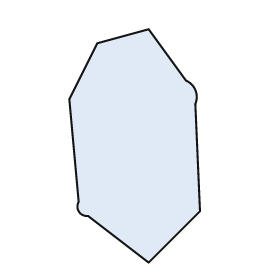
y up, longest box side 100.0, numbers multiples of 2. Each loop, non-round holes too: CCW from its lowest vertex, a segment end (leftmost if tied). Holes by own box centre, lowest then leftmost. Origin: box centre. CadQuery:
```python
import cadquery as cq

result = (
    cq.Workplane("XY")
    .moveTo(6.0, -50.0)
    .lineTo(28.0, -28.0)
    .lineTo(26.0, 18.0)
    .threePointArc((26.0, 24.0), (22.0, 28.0))
    .lineTo(6.0, 50.0)
    .lineTo(-16.0, 44.0)
    .lineTo(-28.0, 20.0)
    .lineTo(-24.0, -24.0)
    .threePointArc((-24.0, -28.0), (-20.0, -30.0))
    .close()
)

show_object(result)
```